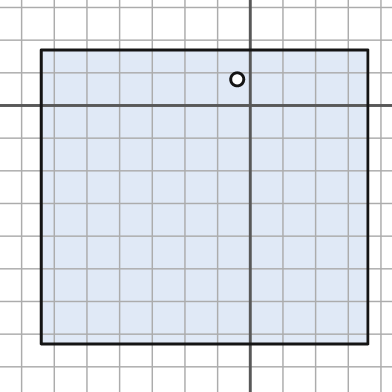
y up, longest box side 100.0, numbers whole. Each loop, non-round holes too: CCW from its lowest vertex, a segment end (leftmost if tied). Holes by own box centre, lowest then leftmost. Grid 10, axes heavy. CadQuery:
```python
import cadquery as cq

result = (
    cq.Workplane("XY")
    .moveTo(-64.0, -73.0)
    .lineTo(36.0, -73.0)
    .lineTo(36.0, 17.0)
    .lineTo(-64.0, 17.0)
    .close()
    .moveTo(-4.0, 8.0)
    .circle(2.0)
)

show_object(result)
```